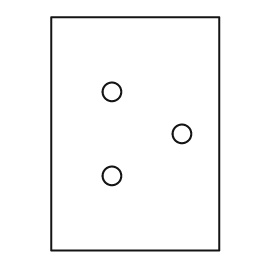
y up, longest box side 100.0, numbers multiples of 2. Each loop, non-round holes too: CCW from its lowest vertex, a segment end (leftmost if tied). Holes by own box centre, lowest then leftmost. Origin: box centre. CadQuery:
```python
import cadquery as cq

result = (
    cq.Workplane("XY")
    .moveTo(-36.0, -50.0)
    .lineTo(36.0, -50.0)
    .lineTo(36.0, 50.0)
    .lineTo(-36.0, 50.0)
    .close()
    .moveTo(-10.0, -18.0)
    .circle(4.0)
    .moveTo(20.0, 0.0)
    .circle(4.0)
    .moveTo(-10.0, 18.0)
    .circle(4.0)
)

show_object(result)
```